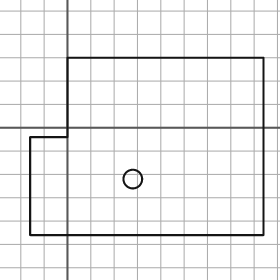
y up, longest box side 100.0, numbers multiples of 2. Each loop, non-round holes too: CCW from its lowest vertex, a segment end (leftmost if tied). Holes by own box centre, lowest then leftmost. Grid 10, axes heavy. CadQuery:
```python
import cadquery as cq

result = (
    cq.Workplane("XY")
    .moveTo(-16.0, -46.0)
    .lineTo(84.0, -46.0)
    .lineTo(84.0, 30.0)
    .lineTo(0.0, 30.0)
    .lineTo(0.0, -4.0)
    .lineTo(-16.0, -4.0)
    .close()
    .moveTo(28.0, -22.0)
    .circle(4.0)
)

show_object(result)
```